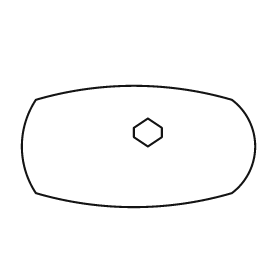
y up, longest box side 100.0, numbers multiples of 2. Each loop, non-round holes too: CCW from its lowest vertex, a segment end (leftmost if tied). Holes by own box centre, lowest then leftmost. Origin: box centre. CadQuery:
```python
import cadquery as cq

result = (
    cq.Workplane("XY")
    .moveTo(-44.0, -20.0)
    .threePointArc((-2.0, -26.0), (40.0, -20.0))
    .threePointArc((50.0, 0.0), (40.0, 20.0))
    .threePointArc((-2.0, 26.0), (-44.0, 20.0))
    .threePointArc((-50.0, 0.0), (-44.0, -20.0))
    .close()
    .moveTo(4.0, 0.0)
    .lineTo(10.0, 4.0)
    .lineTo(10.0, 8.0)
    .lineTo(4.0, 12.0)
    .lineTo(-2.0, 8.0)
    .lineTo(-2.0, 4.0)
    .close()
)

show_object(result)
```